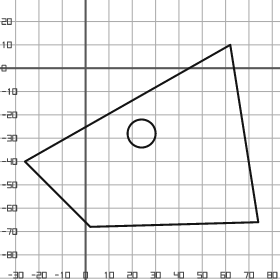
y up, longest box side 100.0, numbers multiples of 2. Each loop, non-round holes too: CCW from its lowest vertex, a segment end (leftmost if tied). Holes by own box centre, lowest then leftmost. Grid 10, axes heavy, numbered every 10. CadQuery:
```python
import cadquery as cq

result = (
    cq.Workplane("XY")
    .moveTo(2.0, -68.0)
    .lineTo(74.0, -66.0)
    .lineTo(62.0, 10.0)
    .lineTo(-26.0, -40.0)
    .close()
    .moveTo(24.0, -28.0)
    .circle(6.0)
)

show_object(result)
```